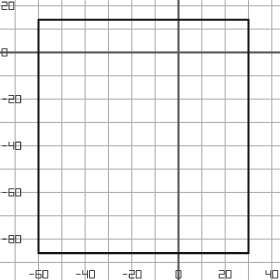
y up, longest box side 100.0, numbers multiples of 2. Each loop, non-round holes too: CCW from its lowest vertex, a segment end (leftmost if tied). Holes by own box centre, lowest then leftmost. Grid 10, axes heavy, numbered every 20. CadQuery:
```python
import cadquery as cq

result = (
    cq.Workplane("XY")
    .moveTo(-60.0, -86.0)
    .lineTo(30.0, -86.0)
    .lineTo(30.0, 14.0)
    .lineTo(-60.0, 14.0)
    .close()
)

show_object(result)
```